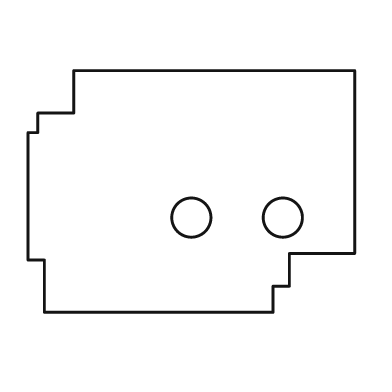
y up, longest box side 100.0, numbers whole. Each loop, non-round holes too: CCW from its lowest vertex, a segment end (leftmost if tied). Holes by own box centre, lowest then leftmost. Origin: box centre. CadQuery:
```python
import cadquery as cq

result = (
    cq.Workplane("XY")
    .moveTo(-45.0, -37.0)
    .lineTo(25.0, -37.0)
    .lineTo(25.0, -29.0)
    .lineTo(30.0, -29.0)
    .lineTo(30.0, -19.0)
    .lineTo(50.0, -19.0)
    .lineTo(50.0, 37.0)
    .lineTo(-36.0, 37.0)
    .lineTo(-36.0, 24.0)
    .lineTo(-47.0, 24.0)
    .lineTo(-47.0, 18.0)
    .lineTo(-50.0, 18.0)
    .lineTo(-50.0, -21.0)
    .lineTo(-45.0, -21.0)
    .close()
    .moveTo(0.0, -8.0)
    .circle(6.0)
    .moveTo(28.0, -8.0)
    .circle(6.0)
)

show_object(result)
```